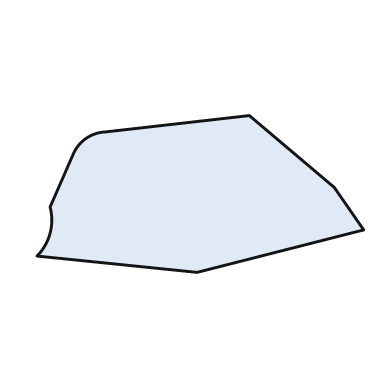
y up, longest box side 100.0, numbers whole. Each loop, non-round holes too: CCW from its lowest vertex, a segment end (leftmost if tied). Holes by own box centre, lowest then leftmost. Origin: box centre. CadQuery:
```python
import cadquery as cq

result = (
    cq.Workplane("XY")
    .moveTo(-1.0, -24.0)
    .lineTo(50.0, -11.0)
    .lineTo(41.0, 2.0)
    .lineTo(15.0, 24.0)
    .lineTo(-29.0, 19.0)
    .threePointArc((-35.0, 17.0), (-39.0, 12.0))
    .lineTo(-46.0, -4.0)
    .threePointArc((-46.0, -12.0), (-50.0, -19.0))
    .close()
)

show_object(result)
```